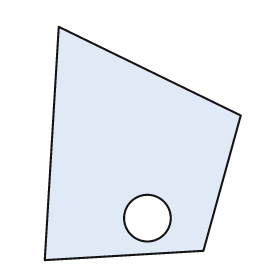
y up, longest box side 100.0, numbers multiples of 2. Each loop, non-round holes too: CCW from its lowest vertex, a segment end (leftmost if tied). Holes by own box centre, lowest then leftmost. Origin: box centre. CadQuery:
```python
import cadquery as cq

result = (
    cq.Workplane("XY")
    .moveTo(-42.0, -50.0)
    .lineTo(26.0, -46.0)
    .lineTo(42.0, 12.0)
    .lineTo(-36.0, 50.0)
    .close()
    .moveTo(2.0, -32.0)
    .circle(10.0)
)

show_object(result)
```